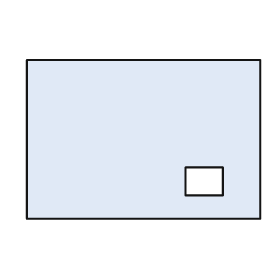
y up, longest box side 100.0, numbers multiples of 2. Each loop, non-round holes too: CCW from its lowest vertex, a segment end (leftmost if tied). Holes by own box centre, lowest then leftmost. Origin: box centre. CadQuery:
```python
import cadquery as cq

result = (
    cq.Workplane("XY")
    .moveTo(-50.0, -34.0)
    .lineTo(50.0, -34.0)
    .lineTo(50.0, 34.0)
    .lineTo(-50.0, 34.0)
    .close()
    .moveTo(18.0, -24.0)
    .lineTo(34.0, -24.0)
    .lineTo(34.0, -12.0)
    .lineTo(18.0, -12.0)
    .close()
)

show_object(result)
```